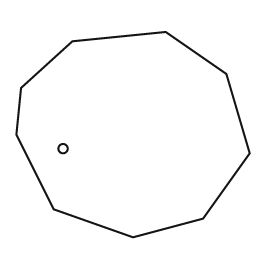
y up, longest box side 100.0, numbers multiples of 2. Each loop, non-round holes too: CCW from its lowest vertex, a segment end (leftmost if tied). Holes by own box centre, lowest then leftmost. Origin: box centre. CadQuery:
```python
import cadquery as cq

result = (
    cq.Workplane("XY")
    .moveTo(0.0, -44.0)
    .lineTo(30.0, -36.0)
    .lineTo(50.0, -8.0)
    .lineTo(40.0, 26.0)
    .lineTo(14.0, 44.0)
    .lineTo(-26.0, 40.0)
    .lineTo(-48.0, 20.0)
    .lineTo(-50.0, 0.0)
    .lineTo(-34.0, -32.0)
    .close()
    .moveTo(-30.0, -6.0)
    .circle(2.0)
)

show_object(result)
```